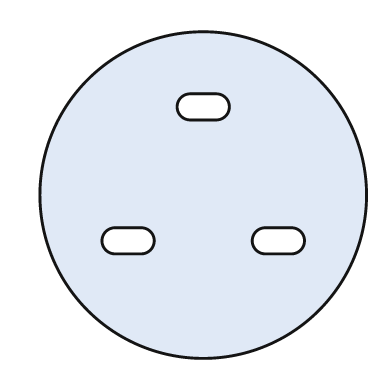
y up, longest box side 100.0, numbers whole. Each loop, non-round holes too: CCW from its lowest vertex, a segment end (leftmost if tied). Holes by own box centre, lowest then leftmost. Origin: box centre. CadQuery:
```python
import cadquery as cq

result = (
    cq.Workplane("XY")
    .moveTo(0.0, 0.0)
    .circle(50.0)
    .moveTo(-27.0, -18.0)
    .lineTo(-19.0, -18.0)
    .threePointArc((-15.0, -14.0), (-19.0, -10.0))
    .lineTo(-27.0, -10.0)
    .threePointArc((-31.0, -14.0), (-27.0, -18.0))
    .close()
    .moveTo(19.0, -18.0)
    .lineTo(27.0, -18.0)
    .threePointArc((31.0, -14.0), (27.0, -10.0))
    .lineTo(19.0, -10.0)
    .threePointArc((15.0, -14.0), (19.0, -18.0))
    .close()
    .moveTo(-4.0, 23.0)
    .lineTo(4.0, 23.0)
    .threePointArc((8.0, 27.0), (4.0, 31.0))
    .lineTo(-4.0, 31.0)
    .threePointArc((-8.0, 27.0), (-4.0, 23.0))
    .close()
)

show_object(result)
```